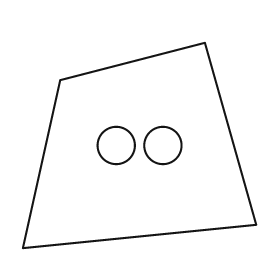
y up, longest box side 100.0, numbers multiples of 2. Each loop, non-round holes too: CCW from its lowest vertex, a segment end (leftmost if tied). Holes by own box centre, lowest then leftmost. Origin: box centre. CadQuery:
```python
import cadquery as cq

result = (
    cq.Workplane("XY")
    .moveTo(-50.0, -44.0)
    .lineTo(50.0, -34.0)
    .lineTo(28.0, 44.0)
    .lineTo(-34.0, 28.0)
    .close()
    .moveTo(-10.0, 0.0)
    .circle(8.0)
    .moveTo(10.0, 0.0)
    .circle(8.0)
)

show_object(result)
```